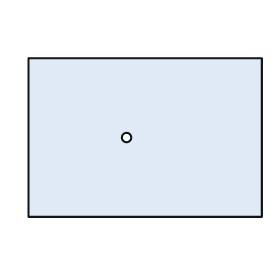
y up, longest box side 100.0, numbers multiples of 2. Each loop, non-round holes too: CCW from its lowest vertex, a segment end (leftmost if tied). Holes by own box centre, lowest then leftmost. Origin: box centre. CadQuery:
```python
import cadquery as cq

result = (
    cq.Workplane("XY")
    .moveTo(-50.0, -34.0)
    .lineTo(50.0, -34.0)
    .lineTo(50.0, 34.0)
    .lineTo(-50.0, 34.0)
    .close()
    .moveTo(-8.0, 0.0)
    .circle(2.0)
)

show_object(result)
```